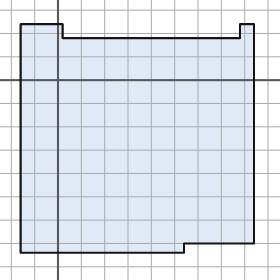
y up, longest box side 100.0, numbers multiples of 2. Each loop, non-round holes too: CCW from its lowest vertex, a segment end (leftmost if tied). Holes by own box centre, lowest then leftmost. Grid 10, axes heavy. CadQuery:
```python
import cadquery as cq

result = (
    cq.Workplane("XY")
    .moveTo(-16.0, -74.0)
    .lineTo(54.0, -74.0)
    .lineTo(54.0, -70.0)
    .lineTo(84.0, -70.0)
    .lineTo(84.0, 24.0)
    .lineTo(78.0, 24.0)
    .lineTo(78.0, 18.0)
    .lineTo(2.0, 18.0)
    .lineTo(2.0, 24.0)
    .lineTo(-16.0, 24.0)
    .close()
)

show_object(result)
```